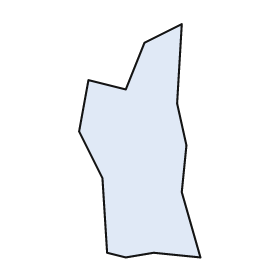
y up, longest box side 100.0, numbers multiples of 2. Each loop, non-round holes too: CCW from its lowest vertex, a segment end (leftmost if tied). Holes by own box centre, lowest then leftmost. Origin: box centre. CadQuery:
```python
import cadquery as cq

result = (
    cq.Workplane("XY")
    .moveTo(-6.0, -50.0)
    .lineTo(6.0, -48.0)
    .lineTo(26.0, -50.0)
    .lineTo(18.0, -22.0)
    .lineTo(20.0, -2.0)
    .lineTo(16.0, 16.0)
    .lineTo(18.0, 50.0)
    .lineTo(2.0, 42.0)
    .lineTo(-6.0, 22.0)
    .lineTo(-22.0, 26.0)
    .lineTo(-26.0, 4.0)
    .lineTo(-16.0, -16.0)
    .lineTo(-14.0, -48.0)
    .close()
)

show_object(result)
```